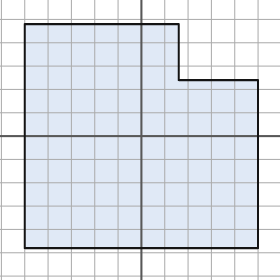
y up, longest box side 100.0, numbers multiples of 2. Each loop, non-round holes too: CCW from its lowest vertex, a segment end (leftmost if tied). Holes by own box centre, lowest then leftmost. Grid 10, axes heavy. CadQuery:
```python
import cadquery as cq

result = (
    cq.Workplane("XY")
    .moveTo(-50.0, -48.0)
    .lineTo(50.0, -48.0)
    .lineTo(50.0, 24.0)
    .lineTo(16.0, 24.0)
    .lineTo(16.0, 48.0)
    .lineTo(-50.0, 48.0)
    .close()
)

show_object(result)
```